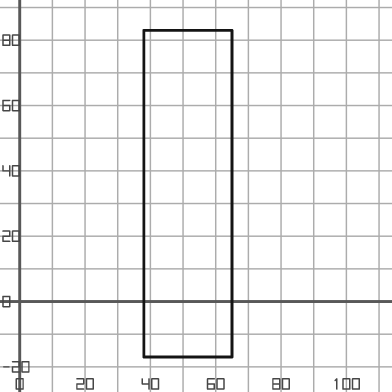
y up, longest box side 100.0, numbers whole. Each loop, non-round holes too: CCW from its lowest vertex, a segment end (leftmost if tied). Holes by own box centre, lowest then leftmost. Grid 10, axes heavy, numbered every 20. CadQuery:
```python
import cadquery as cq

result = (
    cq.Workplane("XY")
    .moveTo(38.0, -17.0)
    .lineTo(65.0, -17.0)
    .lineTo(65.0, 83.0)
    .lineTo(38.0, 83.0)
    .close()
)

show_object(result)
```